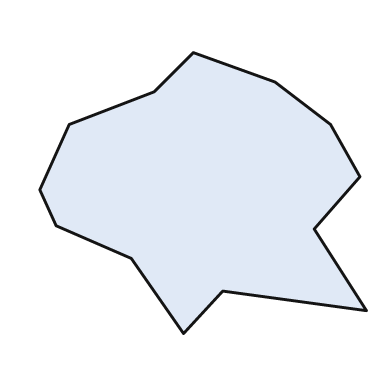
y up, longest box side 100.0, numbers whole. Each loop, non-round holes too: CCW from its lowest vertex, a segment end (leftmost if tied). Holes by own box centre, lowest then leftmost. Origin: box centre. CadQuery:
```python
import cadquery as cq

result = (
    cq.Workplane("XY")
    .moveTo(-6.0, -43.0)
    .lineTo(6.0, -30.0)
    .lineTo(50.0, -36.0)
    .lineTo(34.0, -11.0)
    .lineTo(48.0, 5.0)
    .lineTo(39.0, 21.0)
    .lineTo(22.0, 34.0)
    .lineTo(-3.0, 43.0)
    .lineTo(-15.0, 31.0)
    .lineTo(-41.0, 21.0)
    .lineTo(-50.0, 1.0)
    .lineTo(-45.0, -10.0)
    .lineTo(-22.0, -20.0)
    .close()
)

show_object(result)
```